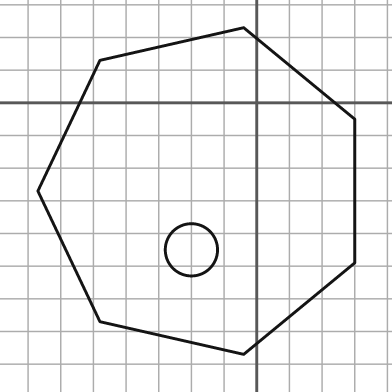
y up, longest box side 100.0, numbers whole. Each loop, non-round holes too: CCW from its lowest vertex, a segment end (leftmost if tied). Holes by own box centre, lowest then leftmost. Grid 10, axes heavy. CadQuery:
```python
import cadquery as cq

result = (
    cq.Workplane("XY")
    .moveTo(-4.0, -77.0)
    .lineTo(30.0, -49.0)
    .lineTo(30.0, -5.0)
    .lineTo(-4.0, 23.0)
    .lineTo(-48.0, 13.0)
    .lineTo(-67.0, -27.0)
    .lineTo(-48.0, -67.0)
    .close()
    .moveTo(-20.0, -45.0)
    .circle(8.0)
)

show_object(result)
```